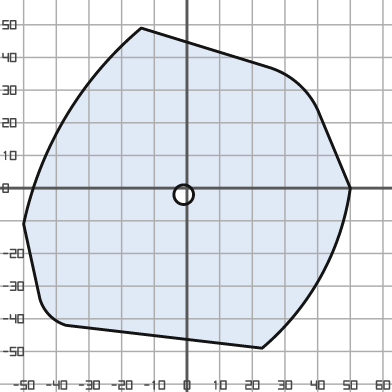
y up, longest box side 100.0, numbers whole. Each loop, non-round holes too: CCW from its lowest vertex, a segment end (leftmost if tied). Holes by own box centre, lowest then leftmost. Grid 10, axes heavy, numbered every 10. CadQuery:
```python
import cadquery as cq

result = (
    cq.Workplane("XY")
    .moveTo(23.0, -49.0)
    .threePointArc((41.0, -27.0), (50.0, 0.0))
    .lineTo(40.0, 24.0)
    .threePointArc((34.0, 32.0), (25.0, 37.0))
    .lineTo(-14.0, 49.0)
    .threePointArc((-37.0, 22.0), (-50.0, -11.0))
    .lineTo(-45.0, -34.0)
    .threePointArc((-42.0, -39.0), (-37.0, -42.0))
    .close()
    .moveTo(-1.0, -2.0)
    .circle(3.0)
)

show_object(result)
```